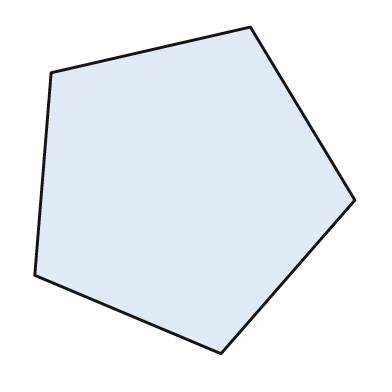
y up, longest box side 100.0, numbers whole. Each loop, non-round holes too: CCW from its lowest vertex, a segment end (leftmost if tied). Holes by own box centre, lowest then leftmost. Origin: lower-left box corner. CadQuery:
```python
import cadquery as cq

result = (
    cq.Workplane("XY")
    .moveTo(57.0, 0.0)
    .lineTo(98.0, 47.0)
    .lineTo(66.0, 100.0)
    .lineTo(5.0, 86.0)
    .lineTo(0.0, 24.0)
    .close()
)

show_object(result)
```